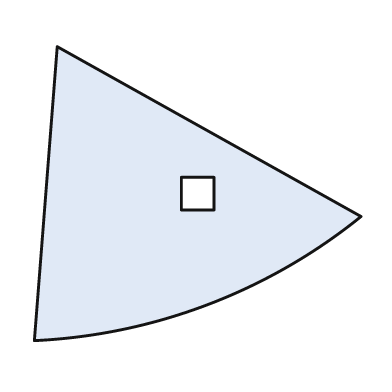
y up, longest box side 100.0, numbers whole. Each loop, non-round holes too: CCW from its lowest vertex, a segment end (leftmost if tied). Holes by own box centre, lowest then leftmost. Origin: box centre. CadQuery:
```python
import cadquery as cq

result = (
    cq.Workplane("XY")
    .moveTo(-50.0, -45.0)
    .threePointArc((3.0, -34.0), (50.0, -7.0))
    .lineTo(-43.0, 45.0)
    .close()
    .moveTo(-5.0, -5.0)
    .lineTo(5.0, -5.0)
    .lineTo(5.0, 5.0)
    .lineTo(-5.0, 5.0)
    .close()
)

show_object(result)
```